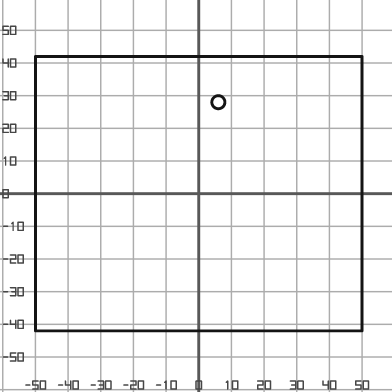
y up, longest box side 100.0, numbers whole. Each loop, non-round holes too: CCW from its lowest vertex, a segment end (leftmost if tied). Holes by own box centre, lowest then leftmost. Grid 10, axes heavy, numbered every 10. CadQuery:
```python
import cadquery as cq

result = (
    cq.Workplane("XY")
    .moveTo(-50.0, -42.0)
    .lineTo(50.0, -42.0)
    .lineTo(50.0, 42.0)
    .lineTo(-50.0, 42.0)
    .close()
    .moveTo(6.0, 28.0)
    .circle(2.0)
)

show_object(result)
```